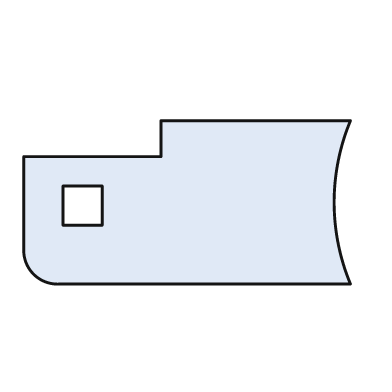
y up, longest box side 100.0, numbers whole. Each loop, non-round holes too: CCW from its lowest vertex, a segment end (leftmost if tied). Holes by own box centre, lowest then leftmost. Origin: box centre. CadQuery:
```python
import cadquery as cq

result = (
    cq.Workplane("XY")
    .moveTo(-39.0, -25.0)
    .lineTo(50.0, -25.0)
    .threePointArc((45.0, 0.0), (50.0, 25.0))
    .lineTo(-8.0, 25.0)
    .lineTo(-8.0, 14.0)
    .lineTo(-50.0, 14.0)
    .lineTo(-50.0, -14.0)
    .threePointArc((-47.0, -22.0), (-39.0, -25.0))
    .close()
    .moveTo(-38.0, -7.0)
    .lineTo(-26.0, -7.0)
    .lineTo(-26.0, 5.0)
    .lineTo(-38.0, 5.0)
    .close()
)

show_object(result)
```